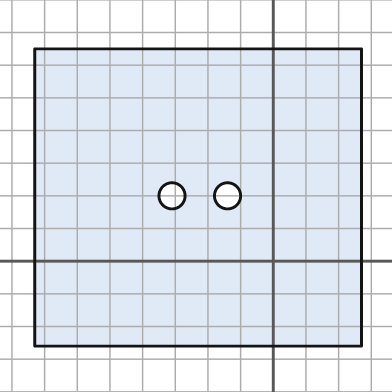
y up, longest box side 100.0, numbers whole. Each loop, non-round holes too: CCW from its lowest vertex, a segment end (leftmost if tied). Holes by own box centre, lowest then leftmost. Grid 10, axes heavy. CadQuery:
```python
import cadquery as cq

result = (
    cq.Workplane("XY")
    .moveTo(-73.0, -26.0)
    .lineTo(27.0, -26.0)
    .lineTo(27.0, 65.0)
    .lineTo(-73.0, 65.0)
    .close()
    .moveTo(-31.0, 20.0)
    .circle(4.0)
    .moveTo(-14.0, 20.0)
    .circle(4.0)
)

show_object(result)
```